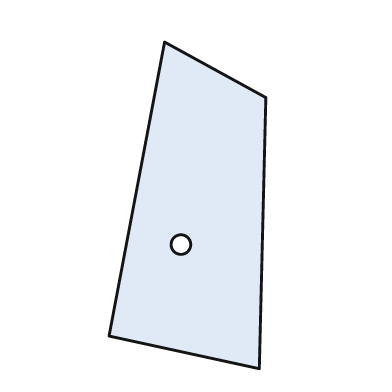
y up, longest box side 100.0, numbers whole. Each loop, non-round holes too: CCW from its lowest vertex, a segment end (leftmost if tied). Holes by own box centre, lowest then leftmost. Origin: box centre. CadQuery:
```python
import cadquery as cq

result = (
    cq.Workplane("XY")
    .moveTo(22.0, -50.0)
    .lineTo(24.0, 33.0)
    .lineTo(-7.0, 50.0)
    .lineTo(-24.0, -40.0)
    .close()
    .moveTo(-2.0, -12.0)
    .circle(3.0)
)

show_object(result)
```